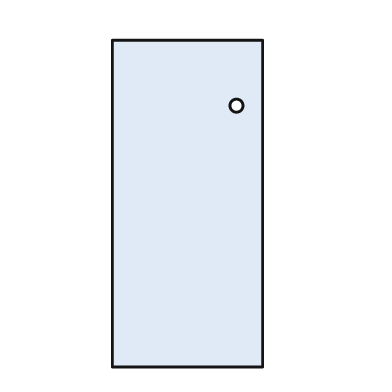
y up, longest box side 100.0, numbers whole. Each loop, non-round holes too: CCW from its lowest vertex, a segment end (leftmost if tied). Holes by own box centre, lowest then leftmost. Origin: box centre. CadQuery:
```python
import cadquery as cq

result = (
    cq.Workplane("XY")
    .moveTo(-23.0, -50.0)
    .lineTo(23.0, -50.0)
    .lineTo(23.0, 50.0)
    .lineTo(-23.0, 50.0)
    .close()
    .moveTo(15.0, 30.0)
    .circle(2.0)
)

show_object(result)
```